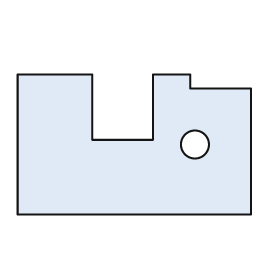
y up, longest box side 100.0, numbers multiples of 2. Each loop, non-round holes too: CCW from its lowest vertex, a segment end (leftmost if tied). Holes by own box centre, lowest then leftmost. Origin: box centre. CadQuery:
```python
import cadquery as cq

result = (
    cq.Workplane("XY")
    .moveTo(-50.0, -30.0)
    .lineTo(50.0, -30.0)
    .lineTo(50.0, 24.0)
    .lineTo(24.0, 24.0)
    .lineTo(24.0, 30.0)
    .lineTo(8.0, 30.0)
    .lineTo(8.0, 2.0)
    .lineTo(-18.0, 2.0)
    .lineTo(-18.0, 30.0)
    .lineTo(-50.0, 30.0)
    .close()
    .moveTo(26.0, 0.0)
    .circle(6.0)
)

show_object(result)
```